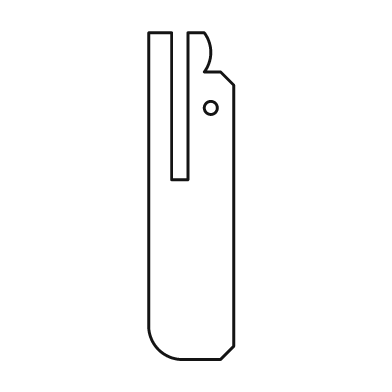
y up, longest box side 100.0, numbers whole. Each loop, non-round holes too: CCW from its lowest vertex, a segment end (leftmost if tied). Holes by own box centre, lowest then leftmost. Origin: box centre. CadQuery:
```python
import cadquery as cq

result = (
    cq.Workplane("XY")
    .moveTo(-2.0, -50.0)
    .lineTo(9.0, -50.0)
    .lineTo(13.0, -46.0)
    .lineTo(13.0, 34.0)
    .lineTo(9.0, 38.0)
    .lineTo(4.0, 38.0)
    .threePointArc((6.0, 44.0), (4.0, 50.0))
    .lineTo(-1.0, 50.0)
    .lineTo(-1.0, 5.0)
    .lineTo(-6.0, 5.0)
    .lineTo(-6.0, 50.0)
    .lineTo(-13.0, 50.0)
    .lineTo(-13.0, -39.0)
    .threePointArc((-10.0, -47.0), (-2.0, -50.0))
    .close()
    .moveTo(6.0, 27.0)
    .circle(2.0)
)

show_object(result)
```